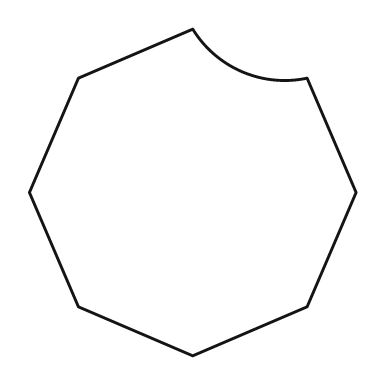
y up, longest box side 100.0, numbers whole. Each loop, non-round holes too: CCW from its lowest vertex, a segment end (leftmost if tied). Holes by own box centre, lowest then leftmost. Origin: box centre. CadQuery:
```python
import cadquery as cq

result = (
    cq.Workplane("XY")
    .moveTo(0.0, -50.0)
    .lineTo(35.0, -35.0)
    .lineTo(50.0, 0.0)
    .lineTo(35.0, 35.0)
    .threePointArc((15.0, 37.0), (0.0, 50.0))
    .lineTo(-35.0, 35.0)
    .lineTo(-50.0, 0.0)
    .lineTo(-35.0, -35.0)
    .close()
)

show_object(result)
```